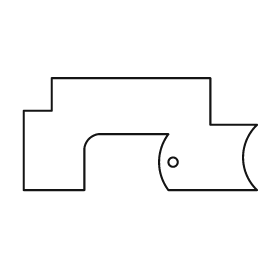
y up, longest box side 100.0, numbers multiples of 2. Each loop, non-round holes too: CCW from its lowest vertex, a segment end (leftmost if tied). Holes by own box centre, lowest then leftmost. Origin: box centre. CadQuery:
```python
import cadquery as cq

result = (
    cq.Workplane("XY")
    .moveTo(-50.0, -24.0)
    .lineTo(-24.0, -24.0)
    .lineTo(-24.0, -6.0)
    .threePointArc((-22.0, -2.0), (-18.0, 0.0))
    .lineTo(12.0, 0.0)
    .threePointArc((8.0, -12.0), (12.0, -24.0))
    .lineTo(50.0, -24.0)
    .threePointArc((44.0, -10.0), (50.0, 4.0))
    .lineTo(30.0, 4.0)
    .lineTo(30.0, 24.0)
    .lineTo(-38.0, 24.0)
    .lineTo(-38.0, 10.0)
    .lineTo(-50.0, 10.0)
    .close()
    .moveTo(14.0, -12.0)
    .circle(2.0)
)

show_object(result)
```